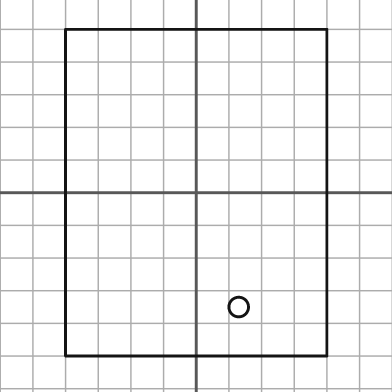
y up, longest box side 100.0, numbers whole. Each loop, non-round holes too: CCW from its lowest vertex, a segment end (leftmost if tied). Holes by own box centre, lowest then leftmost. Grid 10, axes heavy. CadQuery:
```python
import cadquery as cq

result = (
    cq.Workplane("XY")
    .moveTo(-40.0, -50.0)
    .lineTo(40.0, -50.0)
    .lineTo(40.0, 50.0)
    .lineTo(-40.0, 50.0)
    .close()
    .moveTo(13.0, -35.0)
    .circle(3.0)
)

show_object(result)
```